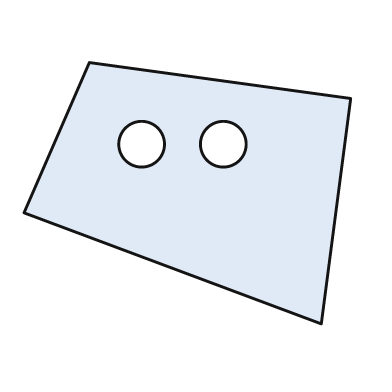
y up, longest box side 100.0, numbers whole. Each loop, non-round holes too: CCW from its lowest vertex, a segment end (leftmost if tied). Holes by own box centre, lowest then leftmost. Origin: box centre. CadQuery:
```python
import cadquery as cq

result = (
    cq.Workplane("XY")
    .moveTo(41.0, -40.0)
    .lineTo(50.0, 29.0)
    .lineTo(-30.0, 40.0)
    .lineTo(-50.0, -6.0)
    .close()
    .moveTo(-14.0, 15.0)
    .circle(7.0)
    .moveTo(11.0, 15.0)
    .circle(7.0)
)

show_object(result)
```